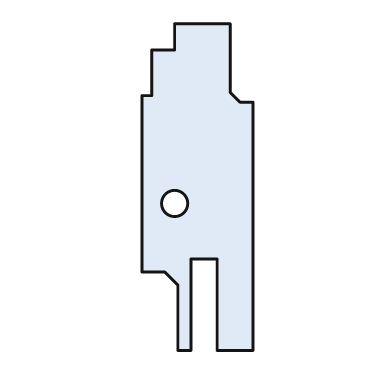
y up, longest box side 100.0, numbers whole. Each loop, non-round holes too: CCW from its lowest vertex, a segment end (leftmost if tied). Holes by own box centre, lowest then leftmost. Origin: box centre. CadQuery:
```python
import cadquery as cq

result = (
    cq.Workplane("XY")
    .moveTo(-6.0, -50.0)
    .lineTo(-2.0, -50.0)
    .lineTo(-2.0, -22.0)
    .lineTo(6.0, -22.0)
    .lineTo(6.0, -50.0)
    .lineTo(17.0, -50.0)
    .lineTo(17.0, 26.0)
    .lineTo(13.0, 26.0)
    .lineTo(10.0, 29.0)
    .lineTo(10.0, 50.0)
    .lineTo(-7.0, 50.0)
    .lineTo(-7.0, 42.0)
    .lineTo(-14.0, 42.0)
    .lineTo(-14.0, 28.0)
    .lineTo(-17.0, 28.0)
    .lineTo(-17.0, -26.0)
    .lineTo(-10.0, -26.0)
    .lineTo(-6.0, -30.0)
    .close()
    .moveTo(-7.0, -5.0)
    .circle(4.0)
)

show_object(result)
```